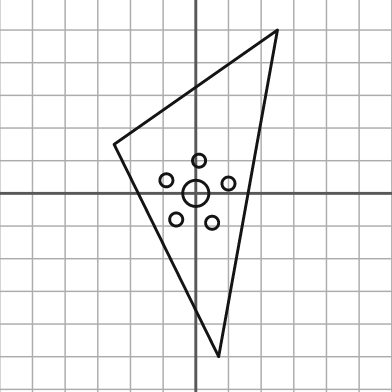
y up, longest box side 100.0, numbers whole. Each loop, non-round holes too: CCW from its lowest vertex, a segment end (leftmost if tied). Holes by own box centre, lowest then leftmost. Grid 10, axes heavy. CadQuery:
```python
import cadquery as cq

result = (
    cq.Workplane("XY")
    .moveTo(7.0, -50.0)
    .lineTo(25.0, 50.0)
    .lineTo(-25.0, 15.0)
    .close()
    .moveTo(5.0, -9.0)
    .circle(2.0)
    .moveTo(-6.0, -8.0)
    .circle(2.0)
    .moveTo(0.0, 0.0)
    .circle(4.0)
    .moveTo(10.0, 3.0)
    .circle(2.0)
    .moveTo(-9.0, 4.0)
    .circle(2.0)
    .moveTo(1.0, 10.0)
    .circle(2.0)
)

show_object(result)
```